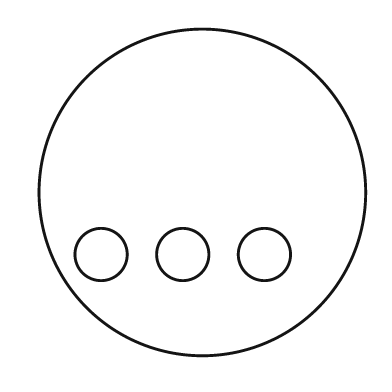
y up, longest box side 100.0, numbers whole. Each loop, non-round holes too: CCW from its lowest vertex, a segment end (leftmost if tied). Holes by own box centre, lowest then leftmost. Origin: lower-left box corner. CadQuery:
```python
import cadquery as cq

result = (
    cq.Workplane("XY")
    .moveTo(50.0, 50.0)
    .circle(50.0)
    .moveTo(19.0, 31.0)
    .circle(8.0)
    .moveTo(44.0, 31.0)
    .circle(8.0)
    .moveTo(69.0, 31.0)
    .circle(8.0)
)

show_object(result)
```